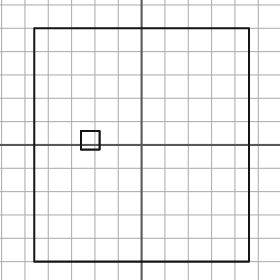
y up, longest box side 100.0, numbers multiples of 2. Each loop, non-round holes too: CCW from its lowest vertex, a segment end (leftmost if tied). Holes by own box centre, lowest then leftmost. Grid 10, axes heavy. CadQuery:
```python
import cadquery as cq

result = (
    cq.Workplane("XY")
    .moveTo(-46.0, -50.0)
    .lineTo(46.0, -50.0)
    .lineTo(46.0, 50.0)
    .lineTo(-46.0, 50.0)
    .close()
    .moveTo(-26.0, -2.0)
    .lineTo(-18.0, -2.0)
    .lineTo(-18.0, 6.0)
    .lineTo(-26.0, 6.0)
    .close()
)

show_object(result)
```